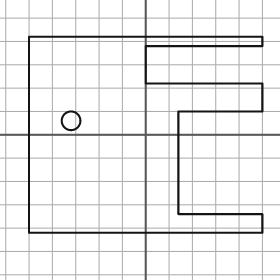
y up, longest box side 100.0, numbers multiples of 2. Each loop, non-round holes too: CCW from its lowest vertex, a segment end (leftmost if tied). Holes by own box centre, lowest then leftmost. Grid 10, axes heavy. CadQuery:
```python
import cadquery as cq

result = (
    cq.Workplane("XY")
    .moveTo(-50.0, -42.0)
    .lineTo(50.0, -42.0)
    .lineTo(50.0, -34.0)
    .lineTo(14.0, -34.0)
    .lineTo(14.0, 10.0)
    .lineTo(50.0, 10.0)
    .lineTo(50.0, 22.0)
    .lineTo(0.0, 22.0)
    .lineTo(0.0, 38.0)
    .lineTo(50.0, 38.0)
    .lineTo(50.0, 42.0)
    .lineTo(-50.0, 42.0)
    .close()
    .moveTo(-32.0, 6.0)
    .circle(4.0)
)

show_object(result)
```